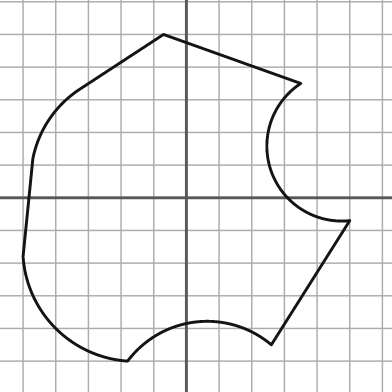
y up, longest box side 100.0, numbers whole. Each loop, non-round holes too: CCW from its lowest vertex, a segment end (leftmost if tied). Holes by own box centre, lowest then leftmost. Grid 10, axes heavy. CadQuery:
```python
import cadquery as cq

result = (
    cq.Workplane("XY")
    .moveTo(-18.0, -50.0)
    .threePointArc((3.0, -38.0), (26.0, -45.0))
    .lineTo(50.0, -7.0)
    .threePointArc((26.0, 8.0), (35.0, 35.0))
    .lineTo(-7.0, 50.0)
    .lineTo(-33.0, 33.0)
    .threePointArc((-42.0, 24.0), (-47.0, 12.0))
    .lineTo(-50.0, -18.0)
    .threePointArc((-40.0, -40.0), (-18.0, -50.0))
    .close()
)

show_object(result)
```